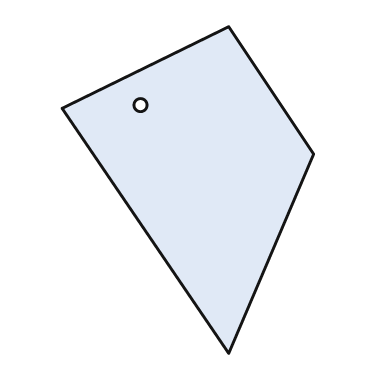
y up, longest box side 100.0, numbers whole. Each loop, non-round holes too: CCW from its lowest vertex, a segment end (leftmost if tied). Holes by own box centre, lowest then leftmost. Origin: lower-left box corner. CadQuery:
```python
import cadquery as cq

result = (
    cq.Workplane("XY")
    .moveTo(51.0, 0.0)
    .lineTo(77.0, 61.0)
    .lineTo(51.0, 100.0)
    .lineTo(0.0, 75.0)
    .close()
    .moveTo(24.0, 76.0)
    .circle(2.0)
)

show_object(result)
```